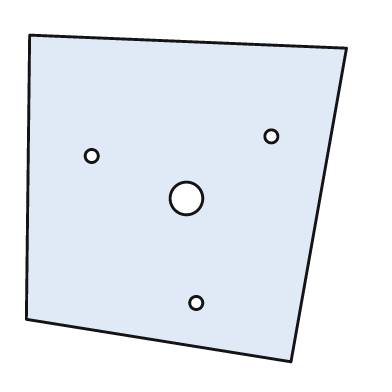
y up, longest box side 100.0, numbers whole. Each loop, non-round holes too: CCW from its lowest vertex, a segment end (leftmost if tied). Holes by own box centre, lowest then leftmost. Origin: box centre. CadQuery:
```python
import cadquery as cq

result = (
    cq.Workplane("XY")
    .moveTo(32.0, -50.0)
    .lineTo(49.0, 46.0)
    .lineTo(-48.0, 50.0)
    .lineTo(-49.0, -37.0)
    .close()
    .moveTo(3.0, -32.0)
    .circle(2.0)
    .moveTo(0.0, 0.0)
    .circle(5.0)
    .moveTo(-29.0, 13.0)
    .circle(2.0)
    .moveTo(26.0, 19.0)
    .circle(2.0)
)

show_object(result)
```